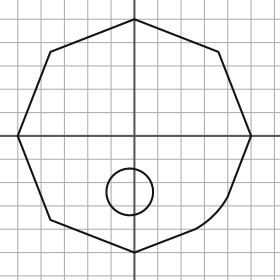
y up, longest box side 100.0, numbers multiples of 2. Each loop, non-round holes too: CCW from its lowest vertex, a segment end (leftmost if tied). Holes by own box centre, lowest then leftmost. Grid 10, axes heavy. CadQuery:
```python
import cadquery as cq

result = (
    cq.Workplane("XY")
    .moveTo(0.0, -50.0)
    .lineTo(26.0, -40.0)
    .threePointArc((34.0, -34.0), (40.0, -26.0))
    .lineTo(50.0, 0.0)
    .lineTo(36.0, 36.0)
    .lineTo(0.0, 50.0)
    .lineTo(-36.0, 36.0)
    .lineTo(-50.0, 0.0)
    .lineTo(-36.0, -36.0)
    .close()
    .moveTo(-2.0, -24.0)
    .circle(10.0)
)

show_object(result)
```